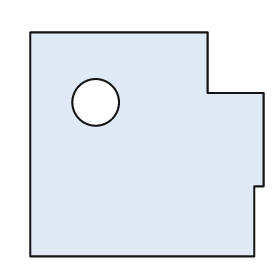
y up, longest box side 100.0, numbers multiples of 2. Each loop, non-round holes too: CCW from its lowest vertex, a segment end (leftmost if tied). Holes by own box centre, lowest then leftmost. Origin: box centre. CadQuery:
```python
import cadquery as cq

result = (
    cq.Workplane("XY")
    .moveTo(-50.0, -48.0)
    .lineTo(46.0, -48.0)
    .lineTo(46.0, -18.0)
    .lineTo(50.0, -18.0)
    .lineTo(50.0, 22.0)
    .lineTo(26.0, 22.0)
    .lineTo(26.0, 48.0)
    .lineTo(-50.0, 48.0)
    .close()
    .moveTo(-22.0, 18.0)
    .circle(10.0)
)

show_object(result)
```